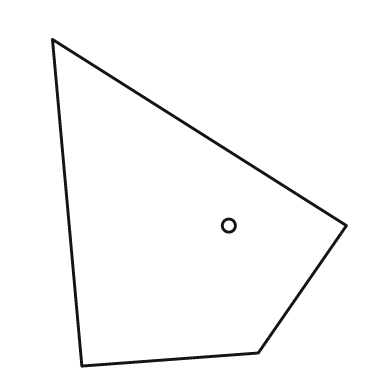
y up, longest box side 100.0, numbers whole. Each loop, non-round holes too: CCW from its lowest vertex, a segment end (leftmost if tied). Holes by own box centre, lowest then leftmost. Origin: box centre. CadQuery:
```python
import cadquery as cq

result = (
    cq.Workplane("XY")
    .moveTo(-36.0, -50.0)
    .lineTo(18.0, -46.0)
    .lineTo(45.0, -7.0)
    .lineTo(-45.0, 50.0)
    .close()
    .moveTo(9.0, -7.0)
    .circle(2.0)
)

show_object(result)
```